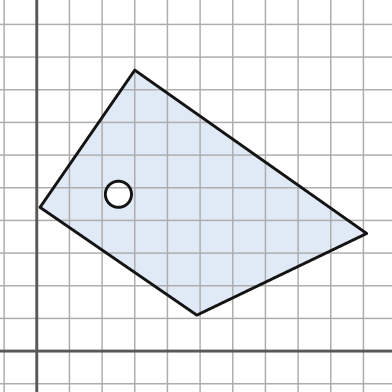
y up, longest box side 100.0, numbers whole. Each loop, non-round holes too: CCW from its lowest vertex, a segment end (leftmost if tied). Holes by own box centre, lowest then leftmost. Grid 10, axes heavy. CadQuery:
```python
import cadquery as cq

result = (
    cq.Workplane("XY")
    .moveTo(49.0, 11.0)
    .lineTo(101.0, 36.0)
    .lineTo(30.0, 86.0)
    .lineTo(1.0, 44.0)
    .close()
    .moveTo(25.0, 48.0)
    .circle(4.0)
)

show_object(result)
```